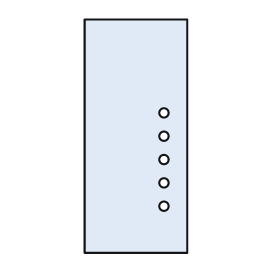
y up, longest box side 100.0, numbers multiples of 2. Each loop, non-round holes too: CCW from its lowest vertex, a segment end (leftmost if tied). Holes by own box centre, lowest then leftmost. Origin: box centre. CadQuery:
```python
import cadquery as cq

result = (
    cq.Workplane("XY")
    .moveTo(-22.0, -50.0)
    .lineTo(22.0, -50.0)
    .lineTo(22.0, 50.0)
    .lineTo(-22.0, 50.0)
    .close()
    .moveTo(12.0, -30.0)
    .circle(2.0)
    .moveTo(12.0, -20.0)
    .circle(2.0)
    .moveTo(12.0, -10.0)
    .circle(2.0)
    .moveTo(12.0, 0.0)
    .circle(2.0)
    .moveTo(12.0, 10.0)
    .circle(2.0)
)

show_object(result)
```